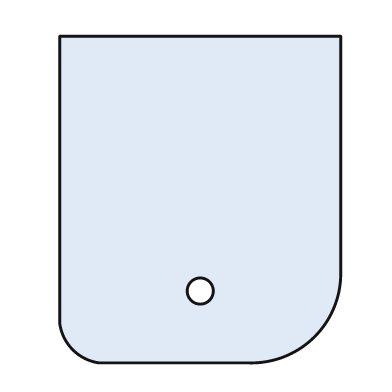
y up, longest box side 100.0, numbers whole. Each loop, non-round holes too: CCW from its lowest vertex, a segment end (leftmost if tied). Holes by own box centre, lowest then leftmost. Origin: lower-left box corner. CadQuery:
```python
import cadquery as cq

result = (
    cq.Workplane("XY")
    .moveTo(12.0, 0.0)
    .lineTo(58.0, 0.0)
    .threePointArc((78.0, 8.0), (86.0, 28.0))
    .lineTo(86.0, 100.0)
    .lineTo(0.0, 100.0)
    .lineTo(0.0, 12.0)
    .threePointArc((4.0, 4.0), (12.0, 0.0))
    .close()
    .moveTo(43.0, 22.0)
    .circle(4.0)
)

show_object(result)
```